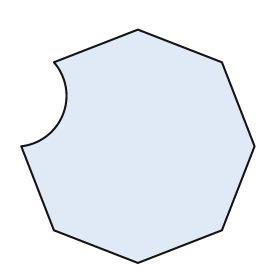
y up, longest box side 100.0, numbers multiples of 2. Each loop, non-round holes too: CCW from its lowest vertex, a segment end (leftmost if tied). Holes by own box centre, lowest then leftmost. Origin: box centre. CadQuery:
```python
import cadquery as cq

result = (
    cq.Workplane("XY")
    .moveTo(0.0, -50.0)
    .lineTo(36.0, -36.0)
    .lineTo(50.0, 0.0)
    .lineTo(36.0, 36.0)
    .lineTo(0.0, 50.0)
    .lineTo(-36.0, 36.0)
    .threePointArc((-32.0, 14.0), (-50.0, 0.0))
    .lineTo(-36.0, -36.0)
    .close()
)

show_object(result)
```